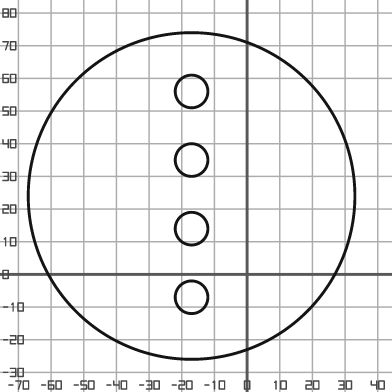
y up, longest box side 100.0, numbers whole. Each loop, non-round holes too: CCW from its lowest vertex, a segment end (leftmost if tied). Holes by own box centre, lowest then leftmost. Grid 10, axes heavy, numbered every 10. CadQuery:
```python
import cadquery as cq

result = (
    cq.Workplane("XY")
    .moveTo(-17.0, 24.0)
    .circle(50.0)
    .moveTo(-17.0, -7.0)
    .circle(5.0)
    .moveTo(-17.0, 14.0)
    .circle(5.0)
    .moveTo(-17.0, 35.0)
    .circle(5.0)
    .moveTo(-17.0, 56.0)
    .circle(5.0)
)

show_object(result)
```